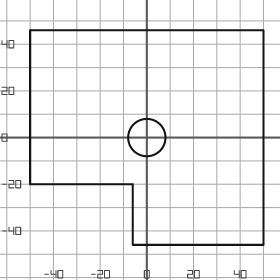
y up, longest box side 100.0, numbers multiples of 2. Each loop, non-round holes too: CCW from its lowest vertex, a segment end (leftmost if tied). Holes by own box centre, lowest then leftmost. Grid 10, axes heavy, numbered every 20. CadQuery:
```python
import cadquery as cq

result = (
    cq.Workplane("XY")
    .moveTo(-6.0, -46.0)
    .lineTo(50.0, -46.0)
    .lineTo(50.0, 46.0)
    .lineTo(-50.0, 46.0)
    .lineTo(-50.0, -20.0)
    .lineTo(-6.0, -20.0)
    .close()
    .moveTo(0.0, 0.0)
    .circle(8.0)
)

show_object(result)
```